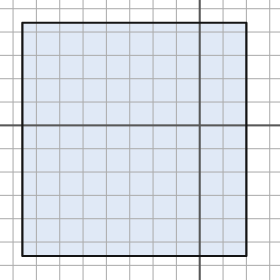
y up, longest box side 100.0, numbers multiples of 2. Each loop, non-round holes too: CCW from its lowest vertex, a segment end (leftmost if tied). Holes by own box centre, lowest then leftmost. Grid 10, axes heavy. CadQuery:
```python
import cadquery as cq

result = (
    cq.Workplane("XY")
    .moveTo(-76.0, -56.0)
    .lineTo(20.0, -56.0)
    .lineTo(20.0, 44.0)
    .lineTo(-76.0, 44.0)
    .close()
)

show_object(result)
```